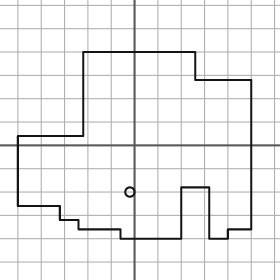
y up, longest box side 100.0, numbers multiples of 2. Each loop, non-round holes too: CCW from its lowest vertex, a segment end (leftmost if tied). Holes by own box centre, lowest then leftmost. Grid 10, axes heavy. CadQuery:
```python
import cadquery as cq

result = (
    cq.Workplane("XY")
    .moveTo(-6.0, -40.0)
    .lineTo(20.0, -40.0)
    .lineTo(20.0, -18.0)
    .lineTo(32.0, -18.0)
    .lineTo(32.0, -40.0)
    .lineTo(40.0, -40.0)
    .lineTo(40.0, -36.0)
    .lineTo(50.0, -36.0)
    .lineTo(50.0, 28.0)
    .lineTo(26.0, 28.0)
    .lineTo(26.0, 40.0)
    .lineTo(-22.0, 40.0)
    .lineTo(-22.0, 4.0)
    .lineTo(-50.0, 4.0)
    .lineTo(-50.0, -26.0)
    .lineTo(-32.0, -26.0)
    .lineTo(-32.0, -32.0)
    .lineTo(-24.0, -32.0)
    .lineTo(-24.0, -36.0)
    .lineTo(-6.0, -36.0)
    .close()
    .moveTo(-2.0, -20.0)
    .circle(2.0)
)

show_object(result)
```